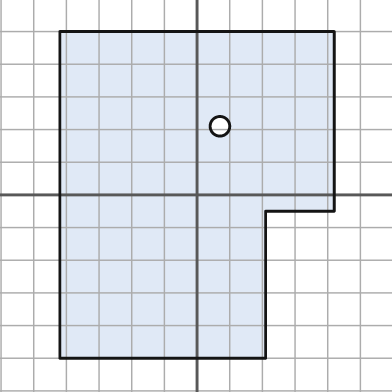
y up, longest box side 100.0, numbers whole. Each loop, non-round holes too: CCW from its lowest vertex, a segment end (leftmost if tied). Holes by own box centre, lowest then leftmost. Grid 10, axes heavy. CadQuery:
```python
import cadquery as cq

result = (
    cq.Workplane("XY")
    .moveTo(-42.0, -50.0)
    .lineTo(21.0, -50.0)
    .lineTo(21.0, -5.0)
    .lineTo(42.0, -5.0)
    .lineTo(42.0, 50.0)
    .lineTo(-42.0, 50.0)
    .close()
    .moveTo(7.0, 21.0)
    .circle(3.0)
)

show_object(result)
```